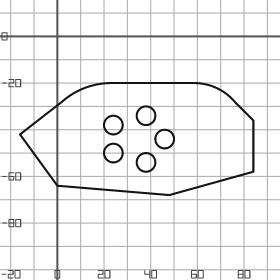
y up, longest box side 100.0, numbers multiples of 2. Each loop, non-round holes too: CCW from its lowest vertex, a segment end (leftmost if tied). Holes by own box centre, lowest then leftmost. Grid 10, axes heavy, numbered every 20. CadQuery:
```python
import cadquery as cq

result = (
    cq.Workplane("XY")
    .moveTo(48.0, -68.0)
    .lineTo(84.0, -58.0)
    .lineTo(84.0, -36.0)
    .lineTo(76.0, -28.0)
    .threePointArc((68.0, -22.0), (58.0, -20.0))
    .lineTo(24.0, -20.0)
    .threePointArc((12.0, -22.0), (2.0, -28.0))
    .lineTo(-16.0, -42.0)
    .lineTo(0.0, -64.0)
    .close()
    .moveTo(38.0, -54.0)
    .circle(4.0)
    .moveTo(24.0, -50.0)
    .circle(4.0)
    .moveTo(46.0, -44.0)
    .circle(4.0)
    .moveTo(24.0, -38.0)
    .circle(4.0)
    .moveTo(38.0, -34.0)
    .circle(4.0)
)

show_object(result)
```